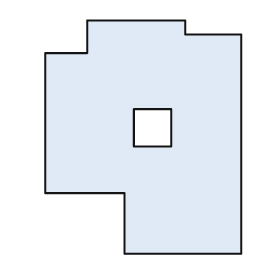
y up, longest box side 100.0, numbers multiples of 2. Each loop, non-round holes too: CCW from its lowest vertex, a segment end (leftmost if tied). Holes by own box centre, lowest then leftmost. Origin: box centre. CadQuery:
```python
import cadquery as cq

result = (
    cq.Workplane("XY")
    .moveTo(-8.0, -50.0)
    .lineTo(42.0, -50.0)
    .lineTo(42.0, 44.0)
    .lineTo(18.0, 44.0)
    .lineTo(18.0, 50.0)
    .lineTo(-24.0, 50.0)
    .lineTo(-24.0, 36.0)
    .lineTo(-42.0, 36.0)
    .lineTo(-42.0, -24.0)
    .lineTo(-8.0, -24.0)
    .close()
    .moveTo(-4.0, -4.0)
    .lineTo(12.0, -4.0)
    .lineTo(12.0, 12.0)
    .lineTo(-4.0, 12.0)
    .close()
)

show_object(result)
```